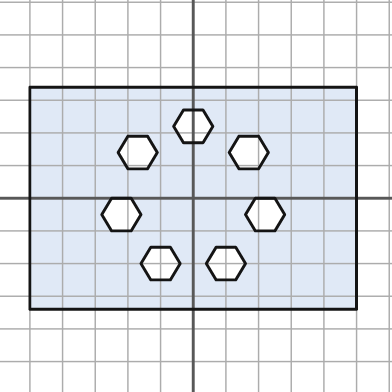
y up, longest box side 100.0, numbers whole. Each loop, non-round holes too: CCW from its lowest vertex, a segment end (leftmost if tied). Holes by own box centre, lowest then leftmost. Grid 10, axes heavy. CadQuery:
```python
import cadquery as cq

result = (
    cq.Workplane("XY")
    .moveTo(-50.0, -34.0)
    .lineTo(50.0, -34.0)
    .lineTo(50.0, 34.0)
    .lineTo(-50.0, 34.0)
    .close()
    .moveTo(-13.0, -25.0)
    .lineTo(-7.0, -25.0)
    .lineTo(-4.0, -20.0)
    .lineTo(-7.0, -15.0)
    .lineTo(-13.0, -15.0)
    .lineTo(-16.0, -20.0)
    .close()
    .moveTo(7.0, -25.0)
    .lineTo(13.0, -25.0)
    .lineTo(16.0, -20.0)
    .lineTo(13.0, -15.0)
    .lineTo(7.0, -15.0)
    .lineTo(4.0, -20.0)
    .close()
    .moveTo(-25.0, -10.0)
    .lineTo(-19.0, -10.0)
    .lineTo(-16.0, -5.0)
    .lineTo(-19.0, 0.0)
    .lineTo(-25.0, 0.0)
    .lineTo(-28.0, -5.0)
    .close()
    .moveTo(19.0, -10.0)
    .lineTo(25.0, -10.0)
    .lineTo(28.0, -5.0)
    .lineTo(25.0, 0.0)
    .lineTo(19.0, 0.0)
    .lineTo(16.0, -5.0)
    .close()
    .moveTo(-20.0, 9.0)
    .lineTo(-14.0, 9.0)
    .lineTo(-11.0, 14.0)
    .lineTo(-14.0, 19.0)
    .lineTo(-20.0, 19.0)
    .lineTo(-23.0, 14.0)
    .close()
    .moveTo(14.0, 9.0)
    .lineTo(20.0, 9.0)
    .lineTo(23.0, 14.0)
    .lineTo(20.0, 19.0)
    .lineTo(14.0, 19.0)
    .lineTo(11.0, 14.0)
    .close()
    .moveTo(-3.0, 17.0)
    .lineTo(3.0, 17.0)
    .lineTo(6.0, 22.0)
    .lineTo(3.0, 27.0)
    .lineTo(-3.0, 27.0)
    .lineTo(-6.0, 22.0)
    .close()
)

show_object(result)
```